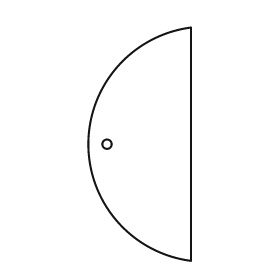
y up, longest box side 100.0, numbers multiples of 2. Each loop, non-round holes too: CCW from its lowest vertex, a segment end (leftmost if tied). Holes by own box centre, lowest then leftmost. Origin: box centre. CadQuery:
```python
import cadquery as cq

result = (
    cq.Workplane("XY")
    .moveTo(22.0, -50.0)
    .lineTo(22.0, 50.0)
    .threePointArc((-22.0, 0.0), (22.0, -50.0))
    .close()
    .moveTo(-14.0, 0.0)
    .circle(2.0)
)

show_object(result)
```